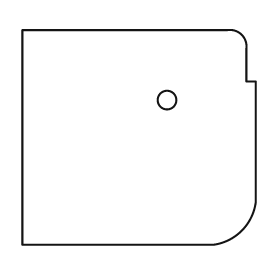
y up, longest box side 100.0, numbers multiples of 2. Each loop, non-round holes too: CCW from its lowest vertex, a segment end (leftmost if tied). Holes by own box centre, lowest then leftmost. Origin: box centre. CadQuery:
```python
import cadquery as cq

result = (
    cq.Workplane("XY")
    .moveTo(-50.0, -46.0)
    .lineTo(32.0, -46.0)
    .threePointArc((44.0, -40.0), (50.0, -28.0))
    .lineTo(50.0, 24.0)
    .lineTo(46.0, 24.0)
    .lineTo(46.0, 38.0)
    .threePointArc((44.0, 44.0), (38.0, 46.0))
    .lineTo(-50.0, 46.0)
    .close()
    .moveTo(12.0, 16.0)
    .circle(4.0)
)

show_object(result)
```